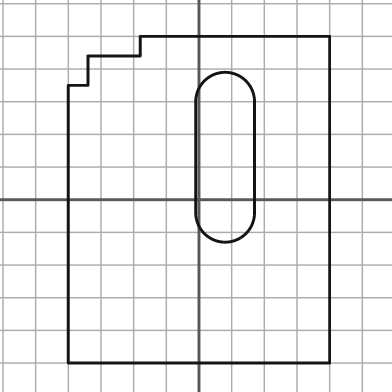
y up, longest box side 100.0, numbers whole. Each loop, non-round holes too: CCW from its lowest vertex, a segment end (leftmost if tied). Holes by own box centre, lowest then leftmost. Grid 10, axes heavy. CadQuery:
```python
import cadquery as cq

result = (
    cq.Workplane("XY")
    .moveTo(-40.0, -50.0)
    .lineTo(40.0, -50.0)
    .lineTo(40.0, 50.0)
    .lineTo(-18.0, 50.0)
    .lineTo(-18.0, 44.0)
    .lineTo(-34.0, 44.0)
    .lineTo(-34.0, 35.0)
    .lineTo(-40.0, 35.0)
    .close()
    .moveTo(-1.0, -4.0)
    .threePointArc((8.0, -13.0), (17.0, -4.0))
    .lineTo(17.0, 30.0)
    .threePointArc((8.0, 39.0), (-1.0, 30.0))
    .close()
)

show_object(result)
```